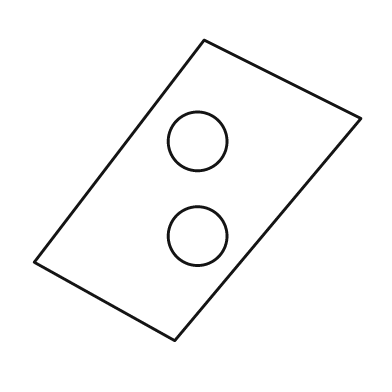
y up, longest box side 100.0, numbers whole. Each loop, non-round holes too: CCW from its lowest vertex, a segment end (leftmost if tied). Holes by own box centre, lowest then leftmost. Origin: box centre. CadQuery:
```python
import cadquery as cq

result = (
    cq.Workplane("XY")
    .moveTo(-7.0, -46.0)
    .lineTo(50.0, 22.0)
    .lineTo(2.0, 46.0)
    .lineTo(-50.0, -22.0)
    .close()
    .moveTo(0.0, -14.0)
    .circle(9.0)
    .moveTo(0.0, 15.0)
    .circle(9.0)
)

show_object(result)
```